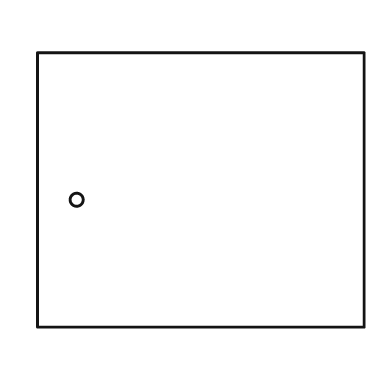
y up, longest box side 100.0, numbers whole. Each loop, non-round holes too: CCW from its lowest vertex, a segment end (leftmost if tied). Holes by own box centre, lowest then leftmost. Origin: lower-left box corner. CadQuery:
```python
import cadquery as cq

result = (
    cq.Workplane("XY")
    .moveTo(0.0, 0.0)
    .lineTo(100.0, 0.0)
    .lineTo(100.0, 84.0)
    .lineTo(0.0, 84.0)
    .close()
    .moveTo(12.0, 39.0)
    .circle(2.0)
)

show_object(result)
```